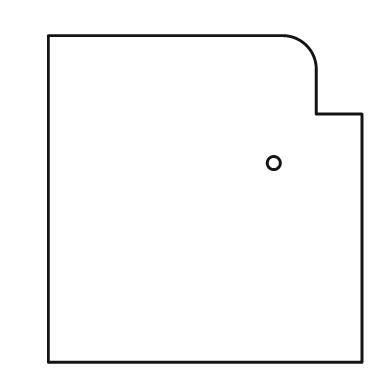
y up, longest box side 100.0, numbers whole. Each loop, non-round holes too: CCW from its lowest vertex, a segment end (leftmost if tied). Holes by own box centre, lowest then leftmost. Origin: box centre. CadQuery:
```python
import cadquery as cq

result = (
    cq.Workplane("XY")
    .moveTo(-48.0, -50.0)
    .lineTo(48.0, -50.0)
    .lineTo(48.0, 26.0)
    .lineTo(34.0, 26.0)
    .lineTo(34.0, 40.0)
    .threePointArc((31.0, 47.0), (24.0, 50.0))
    .lineTo(-48.0, 50.0)
    .close()
    .moveTo(21.0, 11.0)
    .circle(2.0)
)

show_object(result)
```